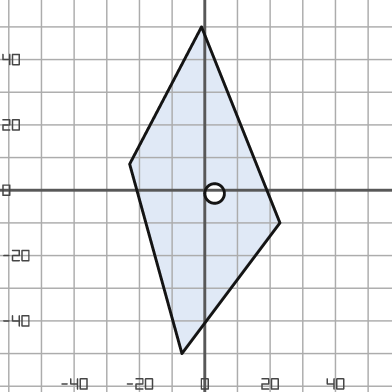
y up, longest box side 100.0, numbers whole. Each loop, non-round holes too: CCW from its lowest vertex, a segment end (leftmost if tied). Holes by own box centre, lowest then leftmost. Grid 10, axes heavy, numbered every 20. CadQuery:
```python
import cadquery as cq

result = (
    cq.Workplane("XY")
    .moveTo(-7.0, -50.0)
    .lineTo(23.0, -10.0)
    .lineTo(-1.0, 50.0)
    .lineTo(-23.0, 8.0)
    .close()
    .moveTo(3.0, -1.0)
    .circle(3.0)
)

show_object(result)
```